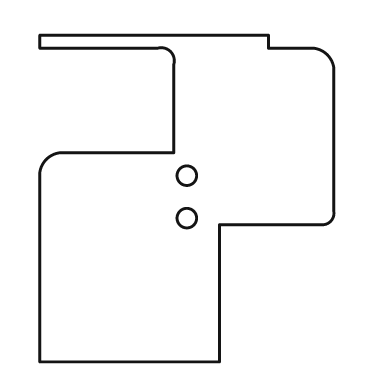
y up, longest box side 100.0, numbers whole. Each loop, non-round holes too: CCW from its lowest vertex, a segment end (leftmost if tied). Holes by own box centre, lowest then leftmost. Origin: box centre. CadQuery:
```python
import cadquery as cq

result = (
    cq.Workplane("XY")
    .moveTo(-45.0, -50.0)
    .lineTo(10.0, -50.0)
    .lineTo(10.0, -8.0)
    .lineTo(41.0, -8.0)
    .threePointArc((44.0, -7.0), (45.0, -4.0))
    .lineTo(45.0, 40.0)
    .threePointArc((43.0, 44.0), (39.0, 46.0))
    .lineTo(25.0, 46.0)
    .lineTo(25.0, 50.0)
    .lineTo(-45.0, 50.0)
    .lineTo(-45.0, 46.0)
    .lineTo(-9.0, 46.0)
    .threePointArc((-5.0, 45.0), (-4.0, 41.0))
    .lineTo(-4.0, 14.0)
    .lineTo(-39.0, 14.0)
    .threePointArc((-43.0, 12.0), (-45.0, 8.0))
    .close()
    .moveTo(0.0, -6.0)
    .circle(3.0)
    .moveTo(0.0, 7.0)
    .circle(3.0)
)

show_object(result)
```